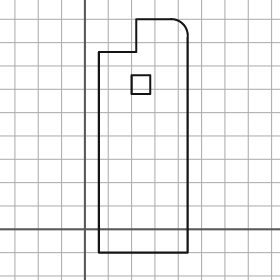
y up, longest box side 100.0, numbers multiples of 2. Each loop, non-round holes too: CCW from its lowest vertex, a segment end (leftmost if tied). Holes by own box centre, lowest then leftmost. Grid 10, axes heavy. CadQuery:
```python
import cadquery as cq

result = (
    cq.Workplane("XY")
    .moveTo(6.0, -10.0)
    .lineTo(44.0, -10.0)
    .lineTo(44.0, 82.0)
    .threePointArc((42.0, 88.0), (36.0, 90.0))
    .lineTo(22.0, 90.0)
    .lineTo(22.0, 76.0)
    .lineTo(6.0, 76.0)
    .close()
    .moveTo(20.0, 58.0)
    .lineTo(28.0, 58.0)
    .lineTo(28.0, 66.0)
    .lineTo(20.0, 66.0)
    .close()
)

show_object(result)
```